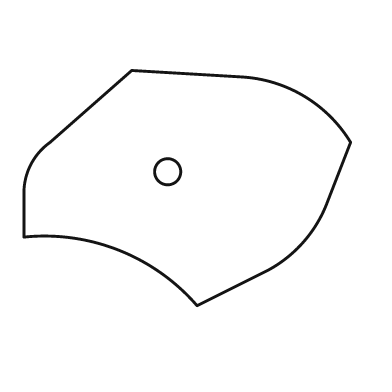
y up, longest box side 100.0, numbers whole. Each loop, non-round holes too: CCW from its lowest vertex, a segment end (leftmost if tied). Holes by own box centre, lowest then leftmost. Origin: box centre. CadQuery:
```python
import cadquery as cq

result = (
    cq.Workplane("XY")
    .moveTo(3.0, -36.0)
    .lineTo(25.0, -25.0)
    .threePointArc((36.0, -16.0), (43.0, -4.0))
    .lineTo(50.0, 14.0)
    .threePointArc((36.0, 28.0), (17.0, 34.0))
    .lineTo(-17.0, 36.0)
    .lineTo(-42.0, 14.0)
    .threePointArc((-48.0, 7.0), (-50.0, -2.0))
    .lineTo(-50.0, -15.0)
    .threePointArc((-21.0, -19.0), (3.0, -36.0))
    .close()
    .moveTo(-6.0, 5.0)
    .circle(4.0)
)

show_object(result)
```